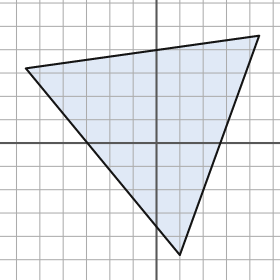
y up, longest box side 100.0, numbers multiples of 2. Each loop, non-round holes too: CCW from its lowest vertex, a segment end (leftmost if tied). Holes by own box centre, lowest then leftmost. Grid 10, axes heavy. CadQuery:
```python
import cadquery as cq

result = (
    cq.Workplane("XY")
    .moveTo(10.0, -48.0)
    .lineTo(44.0, 46.0)
    .lineTo(-56.0, 32.0)
    .close()
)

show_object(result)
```